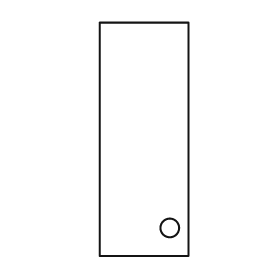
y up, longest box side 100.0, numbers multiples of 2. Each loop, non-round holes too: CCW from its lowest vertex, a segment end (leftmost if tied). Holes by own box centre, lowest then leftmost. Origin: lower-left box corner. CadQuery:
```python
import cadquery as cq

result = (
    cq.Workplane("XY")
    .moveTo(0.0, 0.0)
    .lineTo(38.0, 0.0)
    .lineTo(38.0, 100.0)
    .lineTo(0.0, 100.0)
    .close()
    .moveTo(30.0, 12.0)
    .circle(4.0)
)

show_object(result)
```